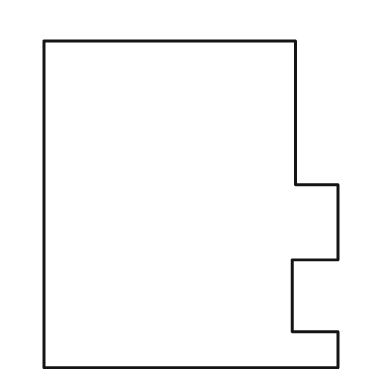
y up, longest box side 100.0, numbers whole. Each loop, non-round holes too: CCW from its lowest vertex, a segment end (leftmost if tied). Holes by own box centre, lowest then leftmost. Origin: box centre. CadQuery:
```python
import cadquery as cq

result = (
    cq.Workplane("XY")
    .moveTo(-45.0, -50.0)
    .lineTo(45.0, -50.0)
    .lineTo(45.0, -39.0)
    .lineTo(31.0, -39.0)
    .lineTo(31.0, -17.0)
    .lineTo(45.0, -17.0)
    .lineTo(45.0, 6.0)
    .lineTo(32.0, 6.0)
    .lineTo(32.0, 50.0)
    .lineTo(-45.0, 50.0)
    .close()
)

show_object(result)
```